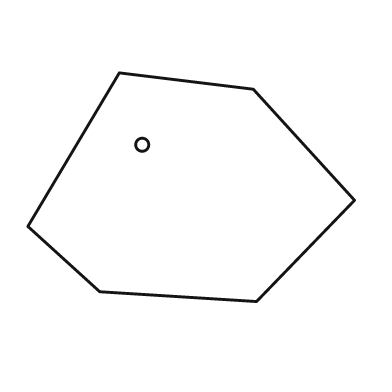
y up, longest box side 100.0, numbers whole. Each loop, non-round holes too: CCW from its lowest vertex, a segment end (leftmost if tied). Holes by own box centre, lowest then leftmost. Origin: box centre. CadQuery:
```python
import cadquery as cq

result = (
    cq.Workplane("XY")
    .moveTo(20.0, -35.0)
    .lineTo(50.0, -4.0)
    .lineTo(19.0, 30.0)
    .lineTo(-22.0, 35.0)
    .lineTo(-50.0, -12.0)
    .lineTo(-28.0, -32.0)
    .close()
    .moveTo(-15.0, 13.0)
    .circle(2.0)
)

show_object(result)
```